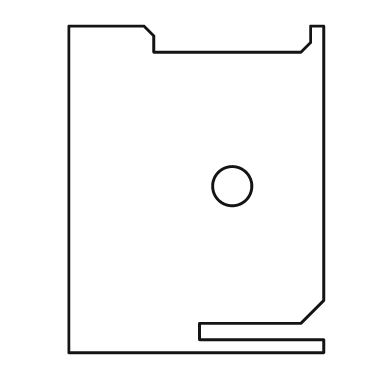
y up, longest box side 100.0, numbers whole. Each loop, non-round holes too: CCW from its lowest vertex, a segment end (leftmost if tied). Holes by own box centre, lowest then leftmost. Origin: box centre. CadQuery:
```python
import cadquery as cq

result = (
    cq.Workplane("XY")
    .moveTo(-39.0, -50.0)
    .lineTo(39.0, -50.0)
    .lineTo(39.0, -46.0)
    .lineTo(1.0, -46.0)
    .lineTo(1.0, -41.0)
    .lineTo(32.0, -41.0)
    .lineTo(39.0, -34.0)
    .lineTo(39.0, 50.0)
    .lineTo(35.0, 50.0)
    .lineTo(35.0, 45.0)
    .lineTo(32.0, 42.0)
    .lineTo(-13.0, 42.0)
    .lineTo(-13.0, 47.0)
    .lineTo(-16.0, 50.0)
    .lineTo(-39.0, 50.0)
    .close()
    .moveTo(11.0, 1.0)
    .circle(6.0)
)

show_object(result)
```